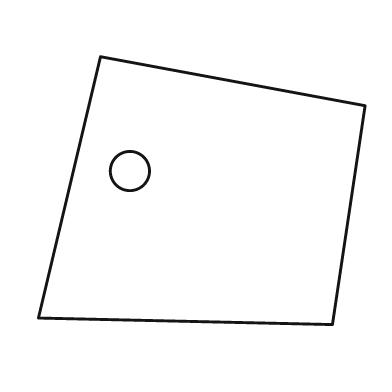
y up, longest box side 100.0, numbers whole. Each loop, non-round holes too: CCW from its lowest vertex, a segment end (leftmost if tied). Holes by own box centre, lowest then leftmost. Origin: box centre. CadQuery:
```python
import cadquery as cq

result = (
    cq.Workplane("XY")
    .moveTo(40.0, -41.0)
    .lineTo(50.0, 26.0)
    .lineTo(-31.0, 41.0)
    .lineTo(-50.0, -39.0)
    .close()
    .moveTo(-22.0, 6.0)
    .circle(6.0)
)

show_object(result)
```